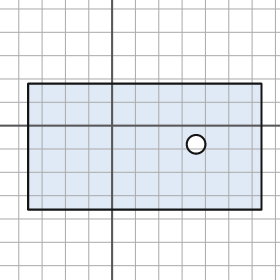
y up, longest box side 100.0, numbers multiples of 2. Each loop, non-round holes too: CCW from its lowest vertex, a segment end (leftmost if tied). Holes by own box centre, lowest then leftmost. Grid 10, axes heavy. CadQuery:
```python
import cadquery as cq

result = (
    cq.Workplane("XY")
    .moveTo(-36.0, -36.0)
    .lineTo(64.0, -36.0)
    .lineTo(64.0, 18.0)
    .lineTo(-36.0, 18.0)
    .close()
    .moveTo(36.0, -8.0)
    .circle(4.0)
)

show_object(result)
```